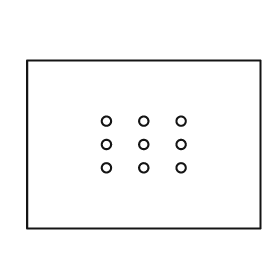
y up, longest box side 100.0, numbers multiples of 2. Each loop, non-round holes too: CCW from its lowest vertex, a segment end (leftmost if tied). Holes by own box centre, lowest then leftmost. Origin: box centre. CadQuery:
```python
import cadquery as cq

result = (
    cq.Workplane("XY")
    .moveTo(-50.0, -36.0)
    .lineTo(50.0, -36.0)
    .lineTo(50.0, 36.0)
    .lineTo(-50.0, 36.0)
    .close()
    .moveTo(-16.0, -10.0)
    .circle(2.0)
    .moveTo(0.0, -10.0)
    .circle(2.0)
    .moveTo(16.0, -10.0)
    .circle(2.0)
    .moveTo(-16.0, 0.0)
    .circle(2.0)
    .moveTo(0.0, 0.0)
    .circle(2.0)
    .moveTo(16.0, 0.0)
    .circle(2.0)
    .moveTo(-16.0, 10.0)
    .circle(2.0)
    .moveTo(0.0, 10.0)
    .circle(2.0)
    .moveTo(16.0, 10.0)
    .circle(2.0)
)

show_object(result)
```